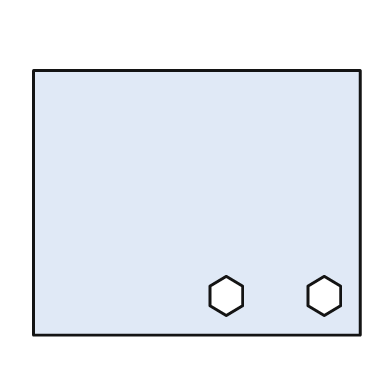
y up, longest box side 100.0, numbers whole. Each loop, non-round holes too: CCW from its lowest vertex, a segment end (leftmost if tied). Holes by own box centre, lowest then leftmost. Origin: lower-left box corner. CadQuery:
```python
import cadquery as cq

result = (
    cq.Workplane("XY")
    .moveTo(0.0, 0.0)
    .lineTo(100.0, 0.0)
    .lineTo(100.0, 81.0)
    .lineTo(0.0, 81.0)
    .close()
    .moveTo(59.0, 6.0)
    .lineTo(64.0, 9.0)
    .lineTo(64.0, 15.0)
    .lineTo(59.0, 18.0)
    .lineTo(54.0, 15.0)
    .lineTo(54.0, 9.0)
    .close()
    .moveTo(89.0, 6.0)
    .lineTo(94.0, 9.0)
    .lineTo(94.0, 15.0)
    .lineTo(89.0, 18.0)
    .lineTo(84.0, 15.0)
    .lineTo(84.0, 9.0)
    .close()
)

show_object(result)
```